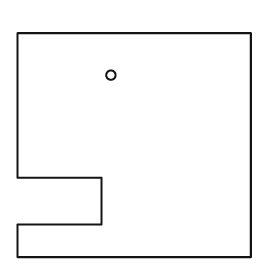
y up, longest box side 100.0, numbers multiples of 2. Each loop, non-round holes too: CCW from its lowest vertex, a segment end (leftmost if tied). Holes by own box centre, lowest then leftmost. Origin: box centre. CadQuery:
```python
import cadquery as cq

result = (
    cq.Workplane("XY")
    .moveTo(-50.0, -48.0)
    .lineTo(50.0, -48.0)
    .lineTo(50.0, 48.0)
    .lineTo(-50.0, 48.0)
    .lineTo(-50.0, -14.0)
    .lineTo(-14.0, -14.0)
    .lineTo(-14.0, -34.0)
    .lineTo(-50.0, -34.0)
    .close()
    .moveTo(-10.0, 30.0)
    .circle(2.0)
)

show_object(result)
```